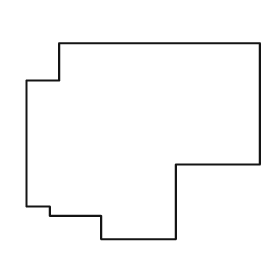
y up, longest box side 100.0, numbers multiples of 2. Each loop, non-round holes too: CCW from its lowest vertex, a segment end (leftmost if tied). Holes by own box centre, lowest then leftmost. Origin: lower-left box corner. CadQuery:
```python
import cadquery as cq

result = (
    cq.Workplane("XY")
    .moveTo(32.0, 0.0)
    .lineTo(64.0, 0.0)
    .lineTo(64.0, 32.0)
    .lineTo(100.0, 32.0)
    .lineTo(100.0, 84.0)
    .lineTo(14.0, 84.0)
    .lineTo(14.0, 68.0)
    .lineTo(0.0, 68.0)
    .lineTo(0.0, 14.0)
    .lineTo(10.0, 14.0)
    .lineTo(10.0, 10.0)
    .lineTo(32.0, 10.0)
    .close()
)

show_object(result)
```